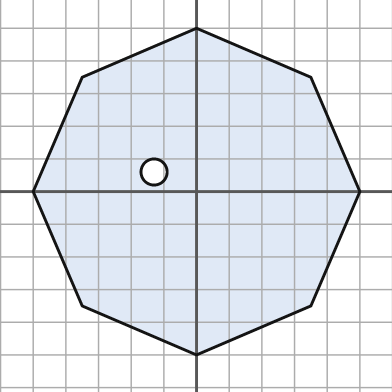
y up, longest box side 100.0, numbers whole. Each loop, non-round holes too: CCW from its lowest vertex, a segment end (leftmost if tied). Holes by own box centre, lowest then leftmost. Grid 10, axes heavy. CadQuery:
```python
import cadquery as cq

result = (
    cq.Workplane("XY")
    .moveTo(0.0, -50.0)
    .lineTo(35.0, -35.0)
    .lineTo(50.0, 0.0)
    .lineTo(35.0, 35.0)
    .lineTo(0.0, 50.0)
    .lineTo(-35.0, 35.0)
    .lineTo(-50.0, 0.0)
    .lineTo(-35.0, -35.0)
    .close()
    .moveTo(-13.0, 6.0)
    .circle(4.0)
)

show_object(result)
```